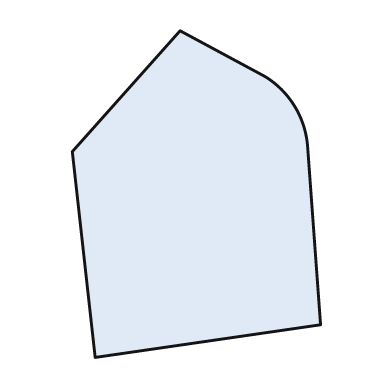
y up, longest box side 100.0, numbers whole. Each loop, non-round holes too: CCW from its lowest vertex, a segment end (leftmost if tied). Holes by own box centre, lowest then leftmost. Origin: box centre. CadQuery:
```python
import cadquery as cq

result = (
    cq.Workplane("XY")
    .moveTo(-31.0, -50.0)
    .lineTo(38.0, -40.0)
    .lineTo(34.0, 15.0)
    .threePointArc((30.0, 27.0), (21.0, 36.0))
    .lineTo(-5.0, 50.0)
    .lineTo(-38.0, 13.0)
    .close()
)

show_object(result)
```